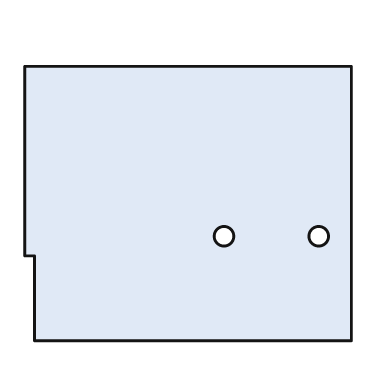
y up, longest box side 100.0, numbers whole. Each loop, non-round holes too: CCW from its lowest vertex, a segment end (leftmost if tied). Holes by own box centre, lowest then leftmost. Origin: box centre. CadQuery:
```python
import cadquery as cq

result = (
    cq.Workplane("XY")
    .moveTo(-47.0, -42.0)
    .lineTo(50.0, -42.0)
    .lineTo(50.0, 42.0)
    .lineTo(-50.0, 42.0)
    .lineTo(-50.0, -16.0)
    .lineTo(-47.0, -16.0)
    .close()
    .moveTo(11.0, -10.0)
    .circle(3.0)
    .moveTo(40.0, -10.0)
    .circle(3.0)
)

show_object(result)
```